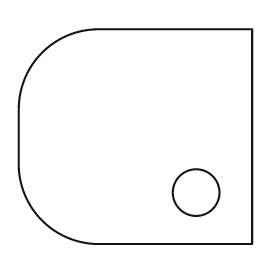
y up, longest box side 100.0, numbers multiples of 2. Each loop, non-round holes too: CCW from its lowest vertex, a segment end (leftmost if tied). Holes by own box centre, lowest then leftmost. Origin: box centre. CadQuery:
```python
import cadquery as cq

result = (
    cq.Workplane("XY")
    .moveTo(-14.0, -46.0)
    .lineTo(50.0, -46.0)
    .lineTo(50.0, 46.0)
    .lineTo(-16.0, 46.0)
    .threePointArc((-40.0, 36.0), (-50.0, 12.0))
    .lineTo(-50.0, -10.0)
    .threePointArc((-40.0, -36.0), (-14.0, -46.0))
    .close()
    .moveTo(26.0, -24.0)
    .circle(10.0)
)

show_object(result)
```